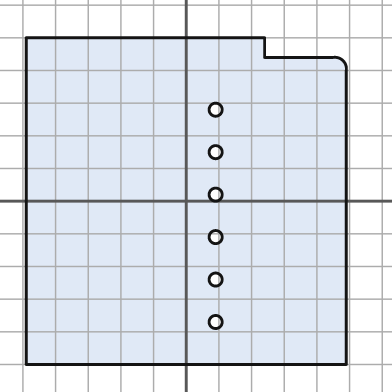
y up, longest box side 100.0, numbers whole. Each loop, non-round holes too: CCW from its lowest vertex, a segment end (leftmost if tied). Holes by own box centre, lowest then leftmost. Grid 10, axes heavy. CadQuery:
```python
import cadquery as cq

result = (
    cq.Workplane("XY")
    .moveTo(-49.0, -50.0)
    .lineTo(49.0, -50.0)
    .lineTo(49.0, 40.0)
    .threePointArc((48.0, 43.0), (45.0, 44.0))
    .lineTo(24.0, 44.0)
    .lineTo(24.0, 50.0)
    .lineTo(-49.0, 50.0)
    .close()
    .moveTo(9.0, -37.0)
    .circle(2.0)
    .moveTo(9.0, -24.0)
    .circle(2.0)
    .moveTo(9.0, -11.0)
    .circle(2.0)
    .moveTo(9.0, 2.0)
    .circle(2.0)
    .moveTo(9.0, 15.0)
    .circle(2.0)
    .moveTo(9.0, 28.0)
    .circle(2.0)
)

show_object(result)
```